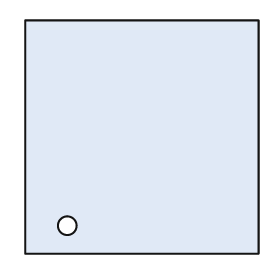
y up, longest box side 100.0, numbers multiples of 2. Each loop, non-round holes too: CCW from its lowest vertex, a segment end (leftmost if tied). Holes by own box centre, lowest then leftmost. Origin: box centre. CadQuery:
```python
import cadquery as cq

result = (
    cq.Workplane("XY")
    .moveTo(-50.0, -50.0)
    .lineTo(50.0, -50.0)
    .lineTo(50.0, 50.0)
    .lineTo(-50.0, 50.0)
    .close()
    .moveTo(-32.0, -38.0)
    .circle(4.0)
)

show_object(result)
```